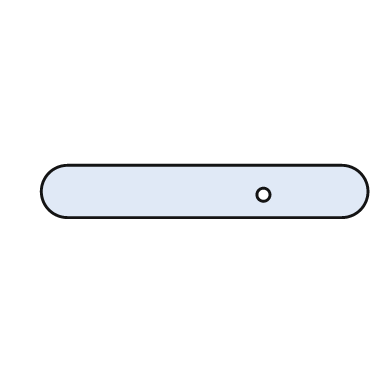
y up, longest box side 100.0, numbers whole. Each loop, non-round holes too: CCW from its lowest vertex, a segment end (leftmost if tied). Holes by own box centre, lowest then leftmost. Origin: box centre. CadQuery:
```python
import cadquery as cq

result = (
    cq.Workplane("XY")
    .moveTo(-42.0, -8.0)
    .lineTo(42.0, -8.0)
    .threePointArc((50.0, 0.0), (42.0, 8.0))
    .lineTo(-42.0, 8.0)
    .threePointArc((-50.0, 0.0), (-42.0, -8.0))
    .close()
    .moveTo(18.0, -1.0)
    .circle(2.0)
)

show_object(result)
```